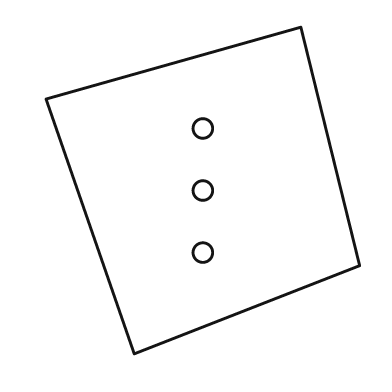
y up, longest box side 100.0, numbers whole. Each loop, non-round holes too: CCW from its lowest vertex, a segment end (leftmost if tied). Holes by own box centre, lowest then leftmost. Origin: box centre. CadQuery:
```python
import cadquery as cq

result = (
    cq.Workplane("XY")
    .moveTo(-21.0, -50.0)
    .lineTo(48.0, -23.0)
    .lineTo(30.0, 50.0)
    .lineTo(-48.0, 28.0)
    .close()
    .moveTo(0.0, -19.0)
    .circle(3.0)
    .moveTo(0.0, 0.0)
    .circle(3.0)
    .moveTo(0.0, 19.0)
    .circle(3.0)
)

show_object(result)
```